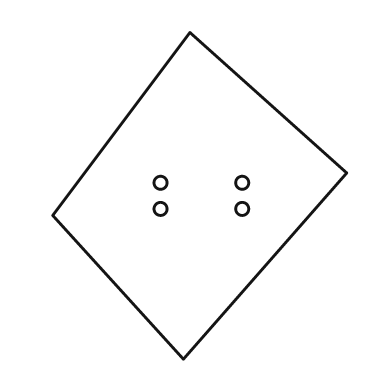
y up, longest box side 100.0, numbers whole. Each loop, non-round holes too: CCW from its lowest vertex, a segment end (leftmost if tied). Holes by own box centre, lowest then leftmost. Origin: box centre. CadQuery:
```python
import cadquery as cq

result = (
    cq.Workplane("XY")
    .moveTo(-5.0, -50.0)
    .lineTo(45.0, 7.0)
    .lineTo(-3.0, 50.0)
    .lineTo(-45.0, -6.0)
    .close()
    .moveTo(-12.0, -4.0)
    .circle(2.0)
    .moveTo(13.0, -4.0)
    .circle(2.0)
    .moveTo(-12.0, 4.0)
    .circle(2.0)
    .moveTo(13.0, 4.0)
    .circle(2.0)
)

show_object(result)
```